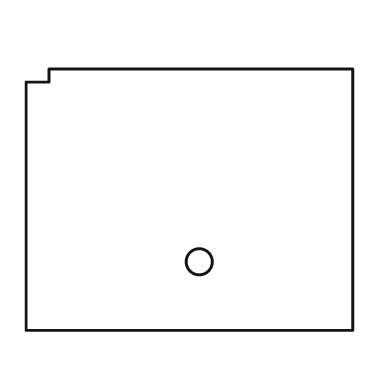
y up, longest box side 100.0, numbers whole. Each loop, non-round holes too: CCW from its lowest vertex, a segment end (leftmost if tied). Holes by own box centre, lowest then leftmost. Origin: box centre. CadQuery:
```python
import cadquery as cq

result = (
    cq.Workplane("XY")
    .moveTo(-50.0, -40.0)
    .lineTo(50.0, -40.0)
    .lineTo(50.0, 40.0)
    .lineTo(-43.0, 40.0)
    .lineTo(-43.0, 36.0)
    .lineTo(-50.0, 36.0)
    .close()
    .moveTo(3.0, -19.0)
    .circle(4.0)
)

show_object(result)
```